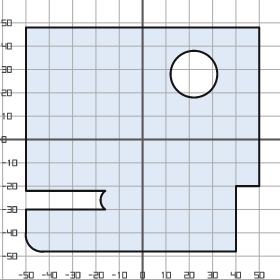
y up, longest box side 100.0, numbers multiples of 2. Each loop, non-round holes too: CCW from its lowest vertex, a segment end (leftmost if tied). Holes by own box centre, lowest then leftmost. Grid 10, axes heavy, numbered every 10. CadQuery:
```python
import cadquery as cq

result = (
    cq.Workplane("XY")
    .moveTo(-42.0, -48.0)
    .lineTo(40.0, -48.0)
    .lineTo(40.0, -20.0)
    .lineTo(50.0, -20.0)
    .lineTo(50.0, 48.0)
    .lineTo(-50.0, 48.0)
    .lineTo(-50.0, -22.0)
    .lineTo(-16.0, -22.0)
    .threePointArc((-18.0, -26.0), (-16.0, -30.0))
    .lineTo(-50.0, -30.0)
    .lineTo(-50.0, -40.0)
    .threePointArc((-48.0, -46.0), (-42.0, -48.0))
    .close()
    .moveTo(22.0, 28.0)
    .circle(10.0)
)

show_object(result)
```